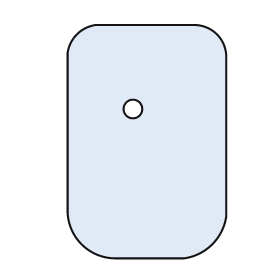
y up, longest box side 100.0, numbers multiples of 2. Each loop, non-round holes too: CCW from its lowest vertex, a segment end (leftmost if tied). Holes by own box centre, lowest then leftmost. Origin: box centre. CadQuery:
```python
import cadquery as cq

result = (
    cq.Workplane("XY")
    .moveTo(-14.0, -50.0)
    .lineTo(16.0, -50.0)
    .threePointArc((28.0, -44.0), (34.0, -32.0))
    .lineTo(34.0, 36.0)
    .threePointArc((30.0, 46.0), (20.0, 50.0))
    .lineTo(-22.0, 50.0)
    .threePointArc((-30.0, 46.0), (-34.0, 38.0))
    .lineTo(-34.0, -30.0)
    .threePointArc((-28.0, -44.0), (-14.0, -50.0))
    .close()
    .moveTo(-6.0, 14.0)
    .circle(4.0)
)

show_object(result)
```